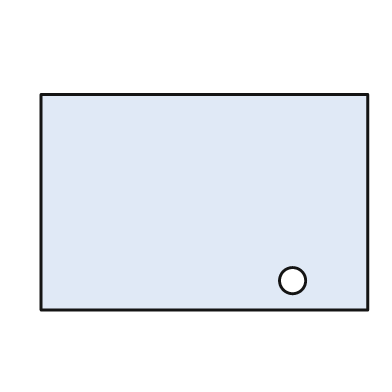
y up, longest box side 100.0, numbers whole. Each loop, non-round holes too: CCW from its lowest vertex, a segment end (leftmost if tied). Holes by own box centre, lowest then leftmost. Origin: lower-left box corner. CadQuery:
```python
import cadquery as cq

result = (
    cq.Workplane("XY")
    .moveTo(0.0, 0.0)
    .lineTo(100.0, 0.0)
    .lineTo(100.0, 66.0)
    .lineTo(0.0, 66.0)
    .close()
    .moveTo(77.0, 9.0)
    .circle(4.0)
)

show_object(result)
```